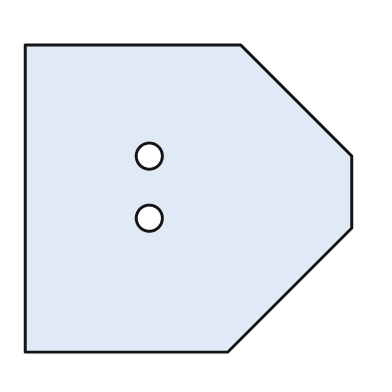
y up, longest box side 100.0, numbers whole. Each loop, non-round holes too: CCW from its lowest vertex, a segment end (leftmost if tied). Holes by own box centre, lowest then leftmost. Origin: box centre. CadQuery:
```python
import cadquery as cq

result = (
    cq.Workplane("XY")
    .moveTo(-50.0, -47.0)
    .lineTo(12.0, -47.0)
    .lineTo(50.0, -9.0)
    .lineTo(50.0, 13.0)
    .lineTo(16.0, 47.0)
    .lineTo(-50.0, 47.0)
    .close()
    .moveTo(-12.0, -6.0)
    .circle(4.0)
    .moveTo(-12.0, 13.0)
    .circle(4.0)
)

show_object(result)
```